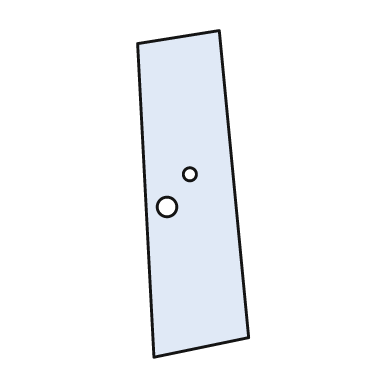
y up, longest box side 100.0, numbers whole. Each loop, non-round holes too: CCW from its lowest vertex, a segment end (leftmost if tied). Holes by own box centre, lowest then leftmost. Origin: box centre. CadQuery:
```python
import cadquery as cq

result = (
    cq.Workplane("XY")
    .moveTo(-12.0, -50.0)
    .lineTo(17.0, -44.0)
    .lineTo(8.0, 50.0)
    .lineTo(-17.0, 46.0)
    .close()
    .moveTo(-8.0, -4.0)
    .circle(3.0)
    .moveTo(-1.0, 6.0)
    .circle(2.0)
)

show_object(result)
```